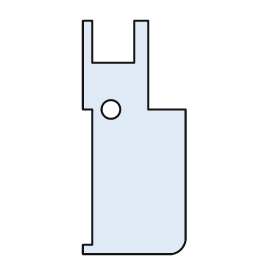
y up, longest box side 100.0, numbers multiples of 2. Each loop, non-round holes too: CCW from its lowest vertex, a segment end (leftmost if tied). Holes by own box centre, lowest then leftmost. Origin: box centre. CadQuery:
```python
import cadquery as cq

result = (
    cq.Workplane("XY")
    .moveTo(-22.0, -50.0)
    .lineTo(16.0, -50.0)
    .threePointArc((20.0, -48.0), (22.0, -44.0))
    .lineTo(22.0, 12.0)
    .lineTo(6.0, 12.0)
    .lineTo(6.0, 50.0)
    .lineTo(0.0, 50.0)
    .lineTo(0.0, 32.0)
    .lineTo(-18.0, 32.0)
    .lineTo(-18.0, 50.0)
    .lineTo(-22.0, 50.0)
    .lineTo(-22.0, 12.0)
    .lineTo(-18.0, 12.0)
    .lineTo(-18.0, -46.0)
    .lineTo(-22.0, -46.0)
    .close()
    .moveTo(-10.0, 12.0)
    .circle(4.0)
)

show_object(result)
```